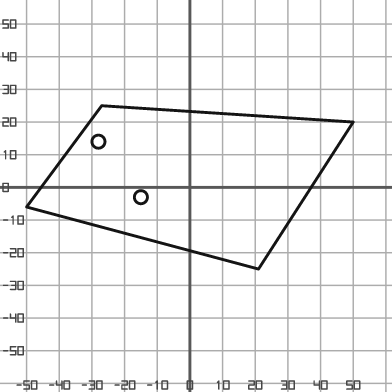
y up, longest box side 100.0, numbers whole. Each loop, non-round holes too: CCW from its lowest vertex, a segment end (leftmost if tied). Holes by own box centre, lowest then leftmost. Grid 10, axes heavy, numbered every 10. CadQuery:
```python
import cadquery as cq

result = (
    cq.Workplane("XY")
    .moveTo(21.0, -25.0)
    .lineTo(50.0, 20.0)
    .lineTo(-27.0, 25.0)
    .lineTo(-50.0, -6.0)
    .close()
    .moveTo(-15.0, -3.0)
    .circle(2.0)
    .moveTo(-28.0, 14.0)
    .circle(2.0)
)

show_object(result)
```